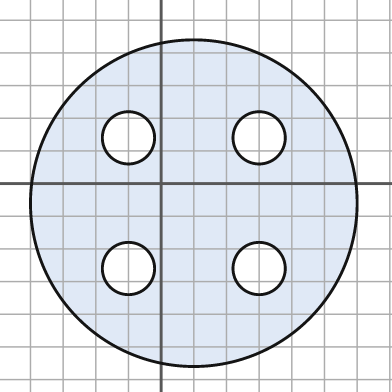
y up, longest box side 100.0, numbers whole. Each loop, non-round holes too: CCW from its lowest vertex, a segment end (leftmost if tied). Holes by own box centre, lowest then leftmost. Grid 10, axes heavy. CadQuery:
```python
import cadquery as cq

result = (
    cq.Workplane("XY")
    .moveTo(10.0, -6.0)
    .circle(50.0)
    .moveTo(-10.0, -26.0)
    .circle(8.0)
    .moveTo(30.0, -26.0)
    .circle(8.0)
    .moveTo(-10.0, 14.0)
    .circle(8.0)
    .moveTo(30.0, 14.0)
    .circle(8.0)
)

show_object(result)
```